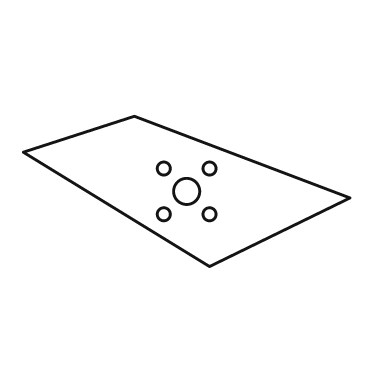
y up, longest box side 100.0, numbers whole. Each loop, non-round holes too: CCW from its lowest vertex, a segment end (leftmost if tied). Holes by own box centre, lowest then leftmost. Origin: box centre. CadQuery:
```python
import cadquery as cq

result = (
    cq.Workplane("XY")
    .moveTo(7.0, -23.0)
    .lineTo(50.0, -2.0)
    .lineTo(-16.0, 23.0)
    .lineTo(-50.0, 12.0)
    .close()
    .moveTo(-7.0, -7.0)
    .circle(2.0)
    .moveTo(7.0, -7.0)
    .circle(2.0)
    .moveTo(0.0, 0.0)
    .circle(4.0)
    .moveTo(-7.0, 7.0)
    .circle(2.0)
    .moveTo(7.0, 7.0)
    .circle(2.0)
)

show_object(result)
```